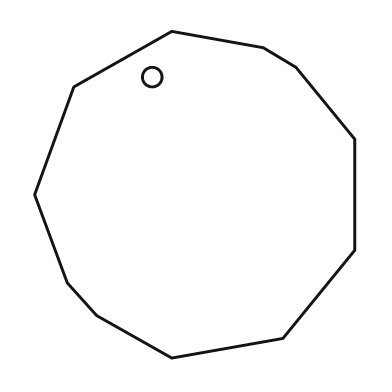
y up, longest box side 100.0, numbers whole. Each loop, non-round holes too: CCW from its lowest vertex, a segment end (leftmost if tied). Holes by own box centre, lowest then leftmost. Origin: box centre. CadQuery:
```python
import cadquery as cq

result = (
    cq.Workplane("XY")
    .moveTo(-7.0, -50.0)
    .lineTo(27.0, -44.0)
    .lineTo(49.0, -17.0)
    .lineTo(49.0, 17.0)
    .lineTo(31.0, 39.0)
    .lineTo(21.0, 45.0)
    .lineTo(-7.0, 50.0)
    .lineTo(-37.0, 33.0)
    .lineTo(-49.0, 0.0)
    .lineTo(-39.0, -27.0)
    .lineTo(-30.0, -37.0)
    .close()
    .moveTo(-13.0, 36.0)
    .circle(3.0)
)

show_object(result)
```